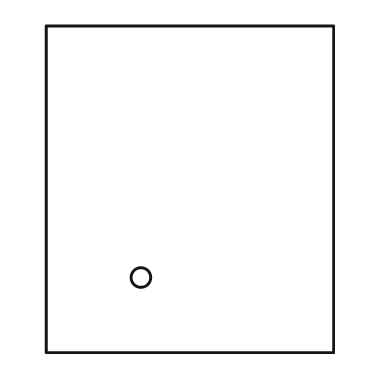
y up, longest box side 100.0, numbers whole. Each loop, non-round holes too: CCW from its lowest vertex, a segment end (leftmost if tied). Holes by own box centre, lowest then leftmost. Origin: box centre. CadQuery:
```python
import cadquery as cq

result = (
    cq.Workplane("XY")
    .moveTo(-44.0, -50.0)
    .lineTo(44.0, -50.0)
    .lineTo(44.0, 50.0)
    .lineTo(-44.0, 50.0)
    .close()
    .moveTo(-15.0, -27.0)
    .circle(3.0)
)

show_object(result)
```